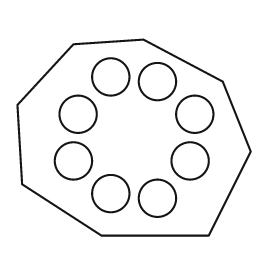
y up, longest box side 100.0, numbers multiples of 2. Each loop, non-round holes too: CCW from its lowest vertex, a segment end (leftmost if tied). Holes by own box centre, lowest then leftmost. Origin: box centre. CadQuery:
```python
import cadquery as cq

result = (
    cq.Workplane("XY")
    .moveTo(-14.0, -42.0)
    .lineTo(32.0, -42.0)
    .lineTo(50.0, -6.0)
    .lineTo(38.0, 24.0)
    .lineTo(4.0, 42.0)
    .lineTo(-26.0, 40.0)
    .lineTo(-50.0, 14.0)
    .lineTo(-48.0, -20.0)
    .close()
    .moveTo(10.0, -26.0)
    .circle(8.0)
    .moveTo(-10.0, -24.0)
    .circle(8.0)
    .moveTo(-26.0, -10.0)
    .circle(8.0)
    .moveTo(24.0, -10.0)
    .circle(8.0)
    .moveTo(-24.0, 10.0)
    .circle(8.0)
    .moveTo(26.0, 10.0)
    .circle(8.0)
    .moveTo(10.0, 24.0)
    .circle(8.0)
    .moveTo(-10.0, 26.0)
    .circle(8.0)
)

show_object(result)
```